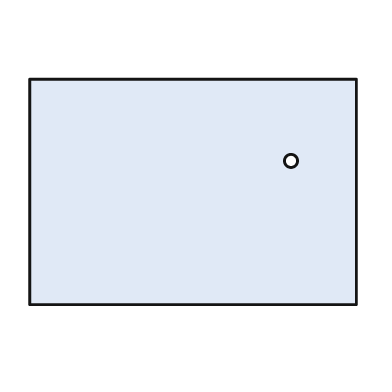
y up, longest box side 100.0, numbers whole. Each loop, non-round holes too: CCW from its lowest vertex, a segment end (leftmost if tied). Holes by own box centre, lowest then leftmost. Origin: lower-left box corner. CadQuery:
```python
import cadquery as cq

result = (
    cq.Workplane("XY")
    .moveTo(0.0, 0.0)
    .lineTo(100.0, 0.0)
    .lineTo(100.0, 69.0)
    .lineTo(0.0, 69.0)
    .close()
    .moveTo(80.0, 44.0)
    .circle(2.0)
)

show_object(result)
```